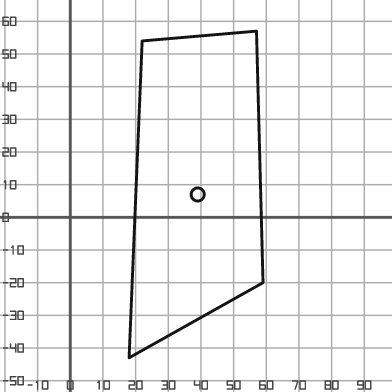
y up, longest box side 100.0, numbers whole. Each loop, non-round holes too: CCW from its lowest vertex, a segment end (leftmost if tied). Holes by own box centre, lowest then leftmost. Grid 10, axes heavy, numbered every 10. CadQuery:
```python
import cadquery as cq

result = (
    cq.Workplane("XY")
    .moveTo(18.0, -43.0)
    .lineTo(59.0, -20.0)
    .lineTo(57.0, 57.0)
    .lineTo(22.0, 54.0)
    .close()
    .moveTo(39.0, 7.0)
    .circle(2.0)
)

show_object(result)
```